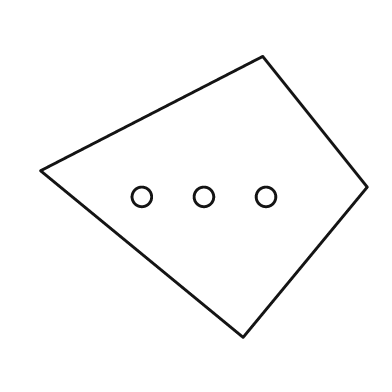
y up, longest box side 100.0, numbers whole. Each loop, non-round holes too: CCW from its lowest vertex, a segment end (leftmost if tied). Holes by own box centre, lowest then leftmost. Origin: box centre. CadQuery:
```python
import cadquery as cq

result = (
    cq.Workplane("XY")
    .moveTo(12.0, -43.0)
    .lineTo(50.0, 3.0)
    .lineTo(18.0, 43.0)
    .lineTo(-50.0, 8.0)
    .close()
    .moveTo(-19.0, 0.0)
    .circle(3.0)
    .moveTo(0.0, 0.0)
    .circle(3.0)
    .moveTo(19.0, 0.0)
    .circle(3.0)
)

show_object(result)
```